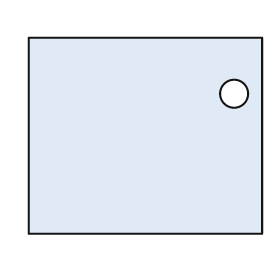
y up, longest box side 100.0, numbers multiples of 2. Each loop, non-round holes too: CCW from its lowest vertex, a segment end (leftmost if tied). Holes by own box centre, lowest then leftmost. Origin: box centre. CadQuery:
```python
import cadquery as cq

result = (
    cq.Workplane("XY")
    .moveTo(-50.0, -42.0)
    .lineTo(50.0, -42.0)
    .lineTo(50.0, 42.0)
    .lineTo(-50.0, 42.0)
    .close()
    .moveTo(38.0, 18.0)
    .circle(6.0)
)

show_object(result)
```